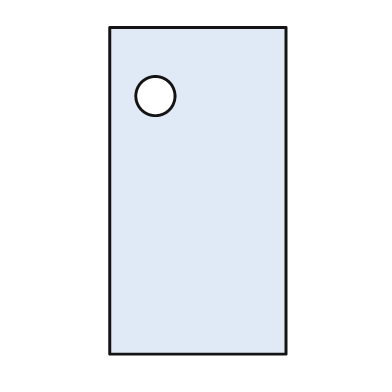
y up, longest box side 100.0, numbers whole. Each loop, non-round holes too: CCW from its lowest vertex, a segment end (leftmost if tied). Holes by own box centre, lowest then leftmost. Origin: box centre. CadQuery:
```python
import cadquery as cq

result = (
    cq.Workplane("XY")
    .moveTo(-27.0, -50.0)
    .lineTo(27.0, -50.0)
    .lineTo(27.0, 50.0)
    .lineTo(-27.0, 50.0)
    .close()
    .moveTo(-13.0, 29.0)
    .circle(6.0)
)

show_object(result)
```